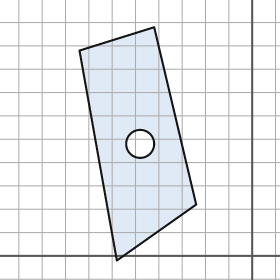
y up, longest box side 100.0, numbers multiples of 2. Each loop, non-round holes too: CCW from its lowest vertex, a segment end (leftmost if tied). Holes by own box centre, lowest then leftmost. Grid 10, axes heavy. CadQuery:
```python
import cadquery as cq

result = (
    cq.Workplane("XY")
    .moveTo(-58.0, -2.0)
    .lineTo(-24.0, 22.0)
    .lineTo(-42.0, 98.0)
    .lineTo(-74.0, 88.0)
    .close()
    .moveTo(-48.0, 48.0)
    .circle(6.0)
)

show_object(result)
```